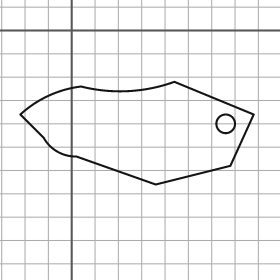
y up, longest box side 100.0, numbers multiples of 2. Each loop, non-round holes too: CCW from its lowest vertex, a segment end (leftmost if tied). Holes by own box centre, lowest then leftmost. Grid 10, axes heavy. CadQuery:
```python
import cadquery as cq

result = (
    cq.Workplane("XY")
    .moveTo(36.0, -66.0)
    .lineTo(68.0, -58.0)
    .lineTo(78.0, -36.0)
    .lineTo(44.0, -22.0)
    .threePointArc((24.0, -26.0), (4.0, -24.0))
    .threePointArc((-10.0, -28.0), (-22.0, -36.0))
    .lineTo(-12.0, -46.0)
    .threePointArc((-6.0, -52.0), (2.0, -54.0))
    .close()
    .moveTo(66.0, -40.0)
    .circle(4.0)
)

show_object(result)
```